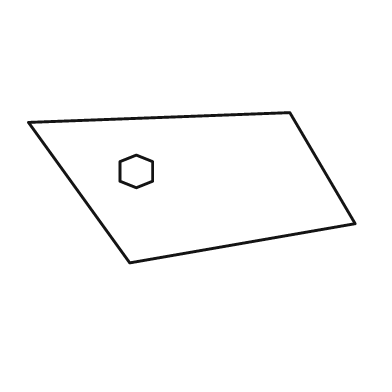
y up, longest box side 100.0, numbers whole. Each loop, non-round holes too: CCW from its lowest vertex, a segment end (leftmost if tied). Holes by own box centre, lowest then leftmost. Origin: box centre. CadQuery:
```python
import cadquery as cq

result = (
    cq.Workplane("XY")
    .moveTo(-19.0, -23.0)
    .lineTo(50.0, -11.0)
    .lineTo(30.0, 23.0)
    .lineTo(-50.0, 20.0)
    .close()
    .moveTo(-17.0, 0.0)
    .lineTo(-12.0, 2.0)
    .lineTo(-12.0, 8.0)
    .lineTo(-17.0, 10.0)
    .lineTo(-22.0, 8.0)
    .lineTo(-22.0, 2.0)
    .close()
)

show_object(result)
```